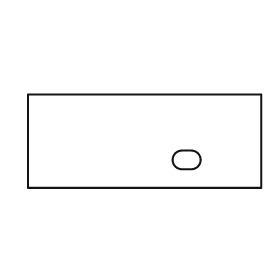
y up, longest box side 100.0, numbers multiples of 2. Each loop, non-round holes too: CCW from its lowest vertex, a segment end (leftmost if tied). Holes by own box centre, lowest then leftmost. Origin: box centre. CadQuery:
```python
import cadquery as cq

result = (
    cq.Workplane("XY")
    .moveTo(-50.0, -20.0)
    .lineTo(50.0, -20.0)
    .lineTo(50.0, 20.0)
    .lineTo(-50.0, 20.0)
    .close()
    .moveTo(16.0, -12.0)
    .lineTo(20.0, -12.0)
    .threePointArc((24.0, -8.0), (20.0, -4.0))
    .lineTo(16.0, -4.0)
    .threePointArc((12.0, -8.0), (16.0, -12.0))
    .close()
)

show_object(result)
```